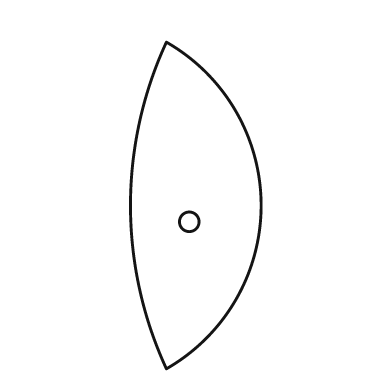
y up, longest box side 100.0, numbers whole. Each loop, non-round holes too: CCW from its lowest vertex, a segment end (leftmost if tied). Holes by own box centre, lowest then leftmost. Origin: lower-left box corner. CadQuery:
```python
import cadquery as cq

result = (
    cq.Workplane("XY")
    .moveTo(11.0, 0.0)
    .threePointArc((40.0, 50.0), (11.0, 100.0))
    .threePointArc((0.0, 50.0), (11.0, 0.0))
    .close()
    .moveTo(18.0, 45.0)
    .circle(3.0)
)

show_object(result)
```